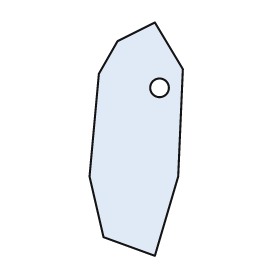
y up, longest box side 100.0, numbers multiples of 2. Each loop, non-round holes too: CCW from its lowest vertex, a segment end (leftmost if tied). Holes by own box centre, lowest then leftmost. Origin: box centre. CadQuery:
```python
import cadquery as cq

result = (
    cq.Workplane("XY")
    .moveTo(8.0, -50.0)
    .lineTo(18.0, -16.0)
    .lineTo(20.0, 30.0)
    .lineTo(8.0, 50.0)
    .lineTo(-8.0, 42.0)
    .lineTo(-16.0, 28.0)
    .lineTo(-20.0, -16.0)
    .lineTo(-14.0, -42.0)
    .close()
    .moveTo(10.0, 22.0)
    .circle(4.0)
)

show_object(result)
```